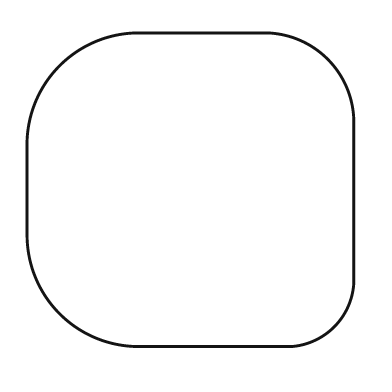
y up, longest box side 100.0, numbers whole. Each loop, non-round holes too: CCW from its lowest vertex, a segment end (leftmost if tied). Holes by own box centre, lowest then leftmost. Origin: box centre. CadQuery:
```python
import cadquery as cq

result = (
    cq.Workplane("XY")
    .moveTo(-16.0, -48.0)
    .lineTo(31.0, -48.0)
    .threePointArc((44.0, -42.0), (50.0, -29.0))
    .lineTo(50.0, 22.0)
    .threePointArc((42.0, 40.0), (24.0, 48.0))
    .lineTo(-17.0, 48.0)
    .threePointArc((-40.0, 38.0), (-50.0, 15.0))
    .lineTo(-50.0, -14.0)
    .threePointArc((-40.0, -38.0), (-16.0, -48.0))
    .close()
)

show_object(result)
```